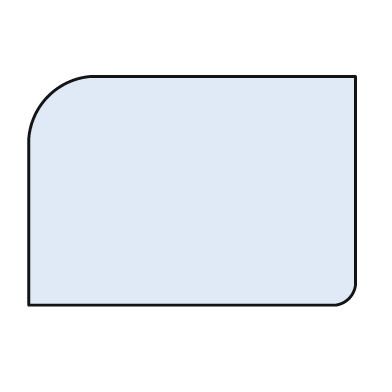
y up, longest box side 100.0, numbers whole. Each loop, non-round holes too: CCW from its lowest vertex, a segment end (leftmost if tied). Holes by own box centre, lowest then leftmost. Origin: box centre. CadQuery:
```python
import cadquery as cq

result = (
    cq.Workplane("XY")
    .moveTo(-50.0, -35.0)
    .lineTo(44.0, -35.0)
    .threePointArc((48.0, -33.0), (50.0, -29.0))
    .lineTo(50.0, 35.0)
    .lineTo(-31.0, 35.0)
    .threePointArc((-44.0, 29.0), (-50.0, 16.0))
    .close()
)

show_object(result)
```